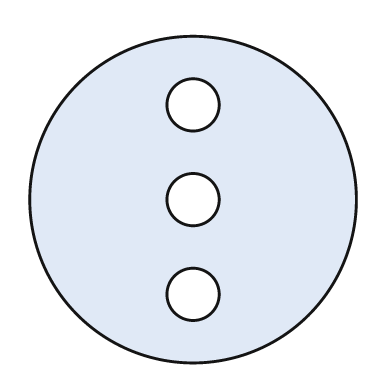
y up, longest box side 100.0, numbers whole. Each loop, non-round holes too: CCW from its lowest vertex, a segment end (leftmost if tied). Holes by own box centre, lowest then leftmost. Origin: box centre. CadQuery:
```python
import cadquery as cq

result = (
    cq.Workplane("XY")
    .moveTo(0.0, 0.0)
    .circle(50.0)
    .moveTo(0.0, -29.0)
    .circle(8.0)
    .moveTo(0.0, 0.0)
    .circle(8.0)
    .moveTo(0.0, 29.0)
    .circle(8.0)
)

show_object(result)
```